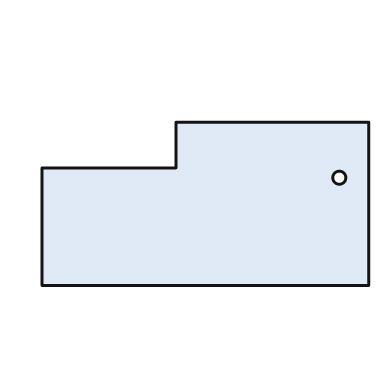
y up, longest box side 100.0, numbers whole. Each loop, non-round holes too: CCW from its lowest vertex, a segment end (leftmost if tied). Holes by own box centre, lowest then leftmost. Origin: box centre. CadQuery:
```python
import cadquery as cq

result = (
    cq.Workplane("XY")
    .moveTo(-50.0, -25.0)
    .lineTo(50.0, -25.0)
    .lineTo(50.0, 25.0)
    .lineTo(-9.0, 25.0)
    .lineTo(-9.0, 11.0)
    .lineTo(-50.0, 11.0)
    .close()
    .moveTo(41.0, 8.0)
    .circle(2.0)
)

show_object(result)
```